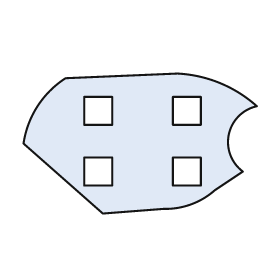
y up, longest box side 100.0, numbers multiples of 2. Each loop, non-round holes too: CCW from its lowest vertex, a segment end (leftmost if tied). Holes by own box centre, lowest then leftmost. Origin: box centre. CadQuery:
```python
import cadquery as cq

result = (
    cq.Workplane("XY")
    .moveTo(-16.0, -30.0)
    .lineTo(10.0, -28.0)
    .threePointArc((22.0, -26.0), (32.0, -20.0))
    .lineTo(44.0, -12.0)
    .threePointArc((38.0, 4.0), (50.0, 16.0))
    .threePointArc((34.0, 26.0), (16.0, 30.0))
    .lineTo(-32.0, 28.0)
    .threePointArc((-44.0, 16.0), (-50.0, 0.0))
    .close()
    .moveTo(-24.0, -18.0)
    .lineTo(-12.0, -18.0)
    .lineTo(-12.0, -6.0)
    .lineTo(-24.0, -6.0)
    .close()
    .moveTo(14.0, -18.0)
    .lineTo(26.0, -18.0)
    .lineTo(26.0, -6.0)
    .lineTo(14.0, -6.0)
    .close()
    .moveTo(-24.0, 8.0)
    .lineTo(-12.0, 8.0)
    .lineTo(-12.0, 20.0)
    .lineTo(-24.0, 20.0)
    .close()
    .moveTo(14.0, 8.0)
    .lineTo(26.0, 8.0)
    .lineTo(26.0, 20.0)
    .lineTo(14.0, 20.0)
    .close()
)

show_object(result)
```